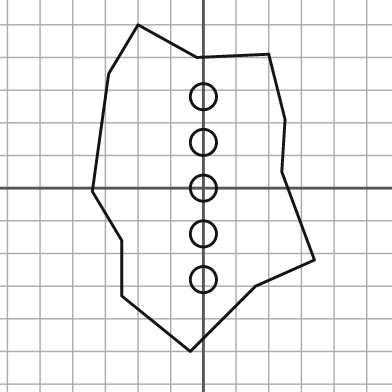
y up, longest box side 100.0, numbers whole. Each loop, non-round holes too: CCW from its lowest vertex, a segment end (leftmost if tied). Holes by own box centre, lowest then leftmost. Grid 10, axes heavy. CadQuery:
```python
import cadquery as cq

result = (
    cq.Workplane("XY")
    .moveTo(-4.0, -50.0)
    .lineTo(16.0, -30.0)
    .lineTo(34.0, -22.0)
    .lineTo(24.0, 5.0)
    .lineTo(25.0, 21.0)
    .lineTo(20.0, 41.0)
    .lineTo(-2.0, 40.0)
    .lineTo(-20.0, 50.0)
    .lineTo(-29.0, 35.0)
    .lineTo(-34.0, -1.0)
    .lineTo(-25.0, -16.0)
    .lineTo(-25.0, -33.0)
    .close()
    .moveTo(0.0, -28.0)
    .circle(4.0)
    .moveTo(0.0, -14.0)
    .circle(4.0)
    .moveTo(0.0, 0.0)
    .circle(4.0)
    .moveTo(0.0, 14.0)
    .circle(4.0)
    .moveTo(0.0, 28.0)
    .circle(4.0)
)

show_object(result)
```